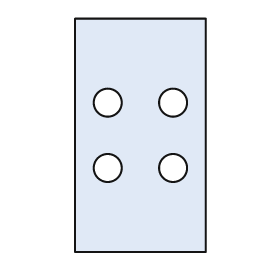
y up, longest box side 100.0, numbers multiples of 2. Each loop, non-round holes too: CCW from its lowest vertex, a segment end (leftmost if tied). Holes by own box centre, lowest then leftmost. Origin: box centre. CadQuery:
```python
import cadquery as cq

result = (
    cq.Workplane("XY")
    .moveTo(-28.0, -50.0)
    .lineTo(28.0, -50.0)
    .lineTo(28.0, 50.0)
    .lineTo(-28.0, 50.0)
    .close()
    .moveTo(-14.0, -14.0)
    .circle(6.0)
    .moveTo(14.0, -14.0)
    .circle(6.0)
    .moveTo(-14.0, 14.0)
    .circle(6.0)
    .moveTo(14.0, 14.0)
    .circle(6.0)
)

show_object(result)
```